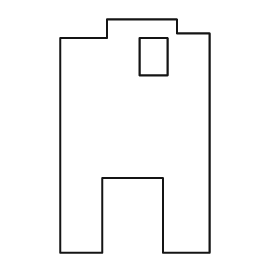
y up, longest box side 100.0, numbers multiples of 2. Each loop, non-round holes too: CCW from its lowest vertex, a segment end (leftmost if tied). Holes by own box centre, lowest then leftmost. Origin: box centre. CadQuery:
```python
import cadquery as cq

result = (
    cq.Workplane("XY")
    .moveTo(-32.0, -50.0)
    .lineTo(-14.0, -50.0)
    .lineTo(-14.0, -18.0)
    .lineTo(12.0, -18.0)
    .lineTo(12.0, -50.0)
    .lineTo(32.0, -50.0)
    .lineTo(32.0, 44.0)
    .lineTo(18.0, 44.0)
    .lineTo(18.0, 50.0)
    .lineTo(-12.0, 50.0)
    .lineTo(-12.0, 42.0)
    .lineTo(-32.0, 42.0)
    .close()
    .moveTo(2.0, 26.0)
    .lineTo(14.0, 26.0)
    .lineTo(14.0, 42.0)
    .lineTo(2.0, 42.0)
    .close()
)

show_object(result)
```